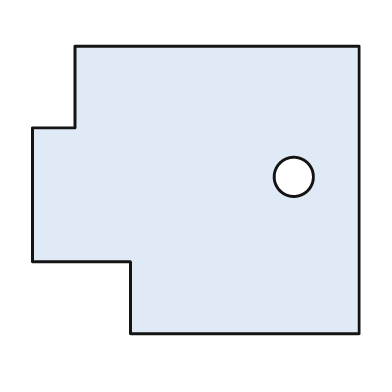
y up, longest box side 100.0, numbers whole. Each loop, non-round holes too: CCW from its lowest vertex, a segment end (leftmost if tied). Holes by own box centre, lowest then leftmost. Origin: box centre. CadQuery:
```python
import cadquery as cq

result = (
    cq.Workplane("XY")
    .moveTo(-20.0, -44.0)
    .lineTo(50.0, -44.0)
    .lineTo(50.0, 44.0)
    .lineTo(-37.0, 44.0)
    .lineTo(-37.0, 19.0)
    .lineTo(-50.0, 19.0)
    .lineTo(-50.0, -22.0)
    .lineTo(-20.0, -22.0)
    .close()
    .moveTo(30.0, 4.0)
    .circle(6.0)
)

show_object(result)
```